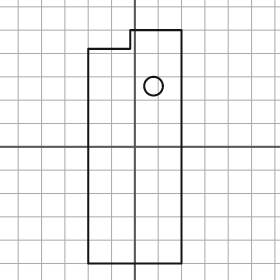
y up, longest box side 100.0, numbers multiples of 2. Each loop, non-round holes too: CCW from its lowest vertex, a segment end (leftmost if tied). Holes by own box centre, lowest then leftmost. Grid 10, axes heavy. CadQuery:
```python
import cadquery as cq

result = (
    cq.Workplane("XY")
    .moveTo(-20.0, -50.0)
    .lineTo(20.0, -50.0)
    .lineTo(20.0, 50.0)
    .lineTo(-2.0, 50.0)
    .lineTo(-2.0, 42.0)
    .lineTo(-20.0, 42.0)
    .close()
    .moveTo(8.0, 26.0)
    .circle(4.0)
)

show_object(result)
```